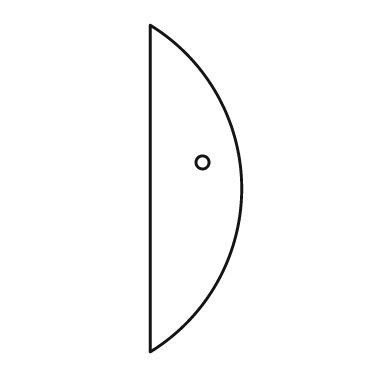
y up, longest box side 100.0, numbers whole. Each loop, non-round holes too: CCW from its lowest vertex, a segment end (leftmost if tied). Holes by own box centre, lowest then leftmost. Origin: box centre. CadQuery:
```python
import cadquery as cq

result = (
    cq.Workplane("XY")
    .moveTo(-14.0, -50.0)
    .threePointArc((14.0, 0.0), (-14.0, 50.0))
    .close()
    .moveTo(2.0, 8.0)
    .circle(2.0)
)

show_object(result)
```